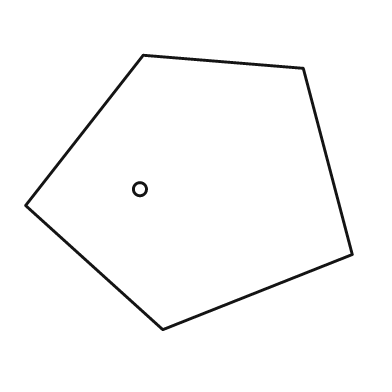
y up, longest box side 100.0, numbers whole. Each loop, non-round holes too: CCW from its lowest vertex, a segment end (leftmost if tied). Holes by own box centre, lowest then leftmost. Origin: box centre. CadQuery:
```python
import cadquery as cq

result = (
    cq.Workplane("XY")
    .moveTo(-8.0, -42.0)
    .lineTo(50.0, -19.0)
    .lineTo(35.0, 38.0)
    .lineTo(-14.0, 42.0)
    .lineTo(-50.0, -4.0)
    .close()
    .moveTo(-15.0, 1.0)
    .circle(2.0)
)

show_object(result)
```